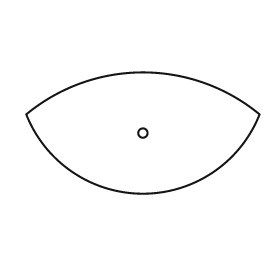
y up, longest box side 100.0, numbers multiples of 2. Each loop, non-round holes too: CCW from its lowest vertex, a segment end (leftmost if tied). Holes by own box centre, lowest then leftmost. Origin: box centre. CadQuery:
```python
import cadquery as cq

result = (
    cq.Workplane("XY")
    .moveTo(-50.0, 8.0)
    .threePointArc((0.0, -26.0), (50.0, 8.0))
    .threePointArc((0.0, 26.0), (-50.0, 8.0))
    .close()
    .moveTo(0.0, 0.0)
    .circle(2.0)
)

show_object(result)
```